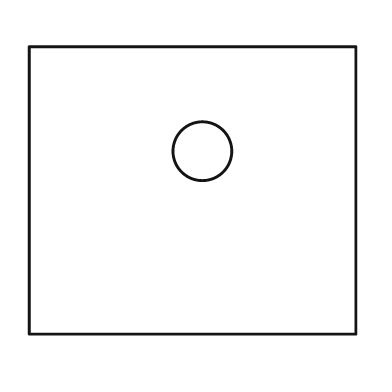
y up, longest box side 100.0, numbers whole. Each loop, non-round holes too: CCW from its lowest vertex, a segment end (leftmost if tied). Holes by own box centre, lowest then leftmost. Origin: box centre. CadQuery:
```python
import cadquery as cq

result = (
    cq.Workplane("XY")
    .moveTo(-50.0, -44.0)
    .lineTo(50.0, -44.0)
    .lineTo(50.0, 44.0)
    .lineTo(-50.0, 44.0)
    .close()
    .moveTo(3.0, 12.0)
    .circle(9.0)
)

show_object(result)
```